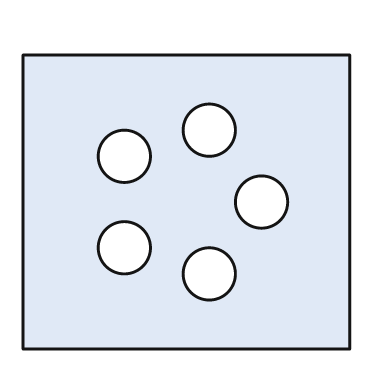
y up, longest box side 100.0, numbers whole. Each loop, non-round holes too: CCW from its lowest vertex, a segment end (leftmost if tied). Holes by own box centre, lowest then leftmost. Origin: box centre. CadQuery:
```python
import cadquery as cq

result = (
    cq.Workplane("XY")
    .moveTo(-50.0, -45.0)
    .lineTo(50.0, -45.0)
    .lineTo(50.0, 45.0)
    .lineTo(-50.0, 45.0)
    .close()
    .moveTo(7.0, -22.0)
    .circle(8.0)
    .moveTo(-19.0, -14.0)
    .circle(8.0)
    .moveTo(23.0, 0.0)
    .circle(8.0)
    .moveTo(-19.0, 14.0)
    .circle(8.0)
    .moveTo(7.0, 22.0)
    .circle(8.0)
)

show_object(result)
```